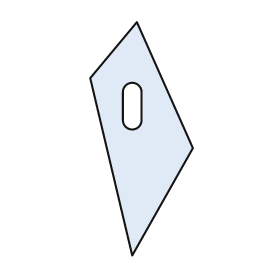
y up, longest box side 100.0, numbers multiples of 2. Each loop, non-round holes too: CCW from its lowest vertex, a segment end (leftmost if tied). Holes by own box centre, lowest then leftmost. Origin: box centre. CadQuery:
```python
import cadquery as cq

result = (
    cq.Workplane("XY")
    .moveTo(-4.0, -50.0)
    .lineTo(22.0, -4.0)
    .lineTo(-2.0, 50.0)
    .lineTo(-22.0, 26.0)
    .close()
    .moveTo(-8.0, 8.0)
    .threePointArc((-4.0, 4.0), (0.0, 8.0))
    .lineTo(0.0, 20.0)
    .threePointArc((-4.0, 24.0), (-8.0, 20.0))
    .close()
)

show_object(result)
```